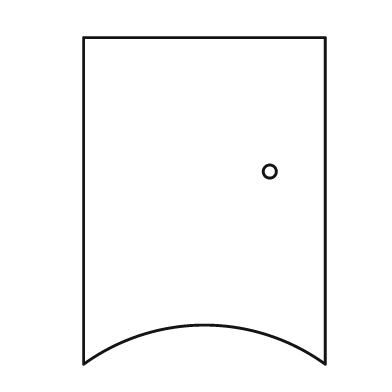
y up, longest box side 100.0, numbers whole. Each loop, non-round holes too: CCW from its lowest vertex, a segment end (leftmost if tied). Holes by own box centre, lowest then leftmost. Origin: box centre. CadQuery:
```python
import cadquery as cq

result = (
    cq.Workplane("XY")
    .moveTo(-37.0, -50.0)
    .threePointArc((0.0, -38.0), (37.0, -50.0))
    .lineTo(37.0, 50.0)
    .lineTo(-37.0, 50.0)
    .close()
    .moveTo(20.0, 9.0)
    .circle(2.0)
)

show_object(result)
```